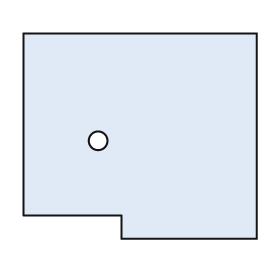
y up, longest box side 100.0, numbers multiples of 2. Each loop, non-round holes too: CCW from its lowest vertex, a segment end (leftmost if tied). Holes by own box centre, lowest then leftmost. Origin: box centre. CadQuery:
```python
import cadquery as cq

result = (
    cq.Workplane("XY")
    .moveTo(-8.0, -44.0)
    .lineTo(50.0, -44.0)
    .lineTo(50.0, 44.0)
    .lineTo(-50.0, 44.0)
    .lineTo(-50.0, -34.0)
    .lineTo(-8.0, -34.0)
    .close()
    .moveTo(-18.0, -2.0)
    .circle(4.0)
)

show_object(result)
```